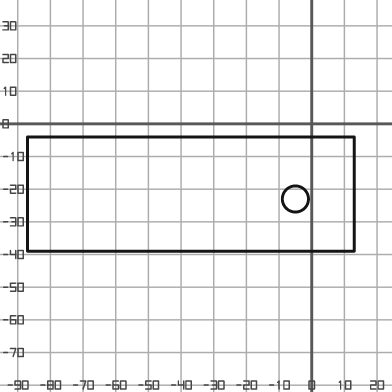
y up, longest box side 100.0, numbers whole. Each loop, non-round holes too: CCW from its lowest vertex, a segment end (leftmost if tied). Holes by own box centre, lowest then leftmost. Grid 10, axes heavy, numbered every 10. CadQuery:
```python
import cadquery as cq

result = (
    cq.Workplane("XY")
    .moveTo(-87.0, -39.0)
    .lineTo(13.0, -39.0)
    .lineTo(13.0, -4.0)
    .lineTo(-87.0, -4.0)
    .close()
    .moveTo(-5.0, -23.0)
    .circle(4.0)
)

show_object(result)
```